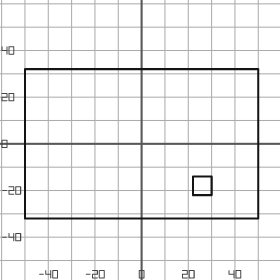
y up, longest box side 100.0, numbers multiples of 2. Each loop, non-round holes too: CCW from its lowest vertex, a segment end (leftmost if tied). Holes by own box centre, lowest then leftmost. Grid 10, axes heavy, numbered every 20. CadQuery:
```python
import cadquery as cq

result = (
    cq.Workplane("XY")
    .moveTo(-50.0, -32.0)
    .lineTo(50.0, -32.0)
    .lineTo(50.0, 32.0)
    .lineTo(-50.0, 32.0)
    .close()
    .moveTo(22.0, -22.0)
    .lineTo(30.0, -22.0)
    .lineTo(30.0, -14.0)
    .lineTo(22.0, -14.0)
    .close()
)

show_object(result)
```